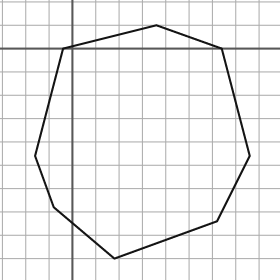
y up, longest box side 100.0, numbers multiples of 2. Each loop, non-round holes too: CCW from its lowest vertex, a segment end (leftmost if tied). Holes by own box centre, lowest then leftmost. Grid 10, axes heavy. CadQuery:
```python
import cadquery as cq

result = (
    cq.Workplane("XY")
    .moveTo(18.0, -90.0)
    .lineTo(62.0, -74.0)
    .lineTo(76.0, -46.0)
    .lineTo(64.0, 0.0)
    .lineTo(36.0, 10.0)
    .lineTo(-4.0, 0.0)
    .lineTo(-16.0, -46.0)
    .lineTo(-8.0, -68.0)
    .close()
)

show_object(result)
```